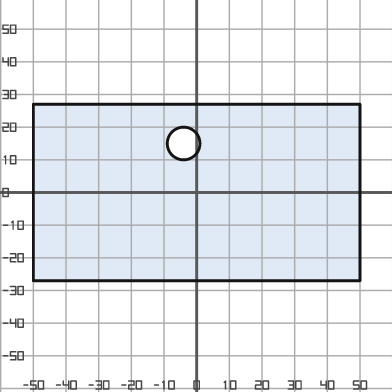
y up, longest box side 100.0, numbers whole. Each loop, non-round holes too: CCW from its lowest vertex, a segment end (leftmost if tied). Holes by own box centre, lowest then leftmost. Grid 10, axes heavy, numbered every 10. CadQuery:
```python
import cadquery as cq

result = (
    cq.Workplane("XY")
    .moveTo(-50.0, -27.0)
    .lineTo(50.0, -27.0)
    .lineTo(50.0, 27.0)
    .lineTo(-50.0, 27.0)
    .close()
    .moveTo(-4.0, 15.0)
    .circle(5.0)
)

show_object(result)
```